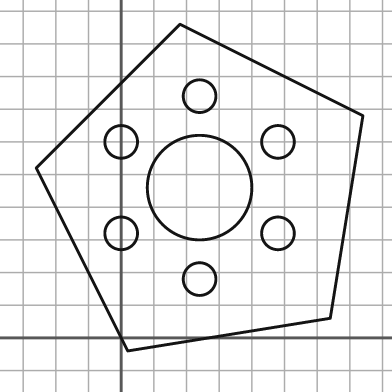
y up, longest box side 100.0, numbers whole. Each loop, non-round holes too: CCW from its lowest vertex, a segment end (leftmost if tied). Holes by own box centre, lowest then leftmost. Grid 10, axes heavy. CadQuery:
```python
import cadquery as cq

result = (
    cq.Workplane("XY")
    .moveTo(2.0, -4.0)
    .lineTo(64.0, 6.0)
    .lineTo(74.0, 68.0)
    .lineTo(18.0, 96.0)
    .lineTo(-26.0, 52.0)
    .close()
    .moveTo(24.0, 18.0)
    .circle(5.0)
    .moveTo(0.0, 32.0)
    .circle(5.0)
    .moveTo(48.0, 32.0)
    .circle(5.0)
    .moveTo(24.0, 46.0)
    .circle(16.0)
    .moveTo(0.0, 60.0)
    .circle(5.0)
    .moveTo(48.0, 60.0)
    .circle(5.0)
    .moveTo(24.0, 74.0)
    .circle(5.0)
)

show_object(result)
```